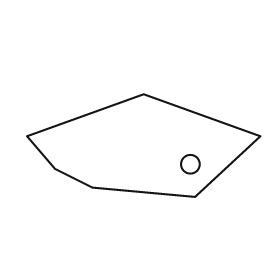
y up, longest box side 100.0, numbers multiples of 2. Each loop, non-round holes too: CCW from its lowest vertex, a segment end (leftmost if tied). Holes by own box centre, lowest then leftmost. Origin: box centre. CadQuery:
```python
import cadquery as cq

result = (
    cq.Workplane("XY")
    .moveTo(22.0, -22.0)
    .lineTo(50.0, 4.0)
    .lineTo(0.0, 22.0)
    .lineTo(-50.0, 4.0)
    .lineTo(-38.0, -10.0)
    .lineTo(-22.0, -18.0)
    .close()
    .moveTo(20.0, -8.0)
    .circle(4.0)
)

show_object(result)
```